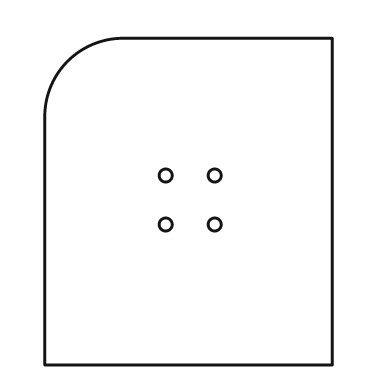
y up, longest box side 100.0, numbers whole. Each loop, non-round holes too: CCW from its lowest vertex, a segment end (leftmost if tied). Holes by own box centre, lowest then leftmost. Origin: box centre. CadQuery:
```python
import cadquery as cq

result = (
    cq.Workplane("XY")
    .moveTo(-44.0, -50.0)
    .lineTo(44.0, -50.0)
    .lineTo(44.0, 50.0)
    .lineTo(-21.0, 50.0)
    .threePointArc((-37.0, 43.0), (-44.0, 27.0))
    .close()
    .moveTo(-7.0, -7.0)
    .circle(2.0)
    .moveTo(8.0, -7.0)
    .circle(2.0)
    .moveTo(-7.0, 8.0)
    .circle(2.0)
    .moveTo(8.0, 8.0)
    .circle(2.0)
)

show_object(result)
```